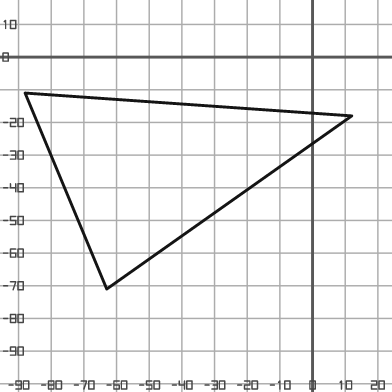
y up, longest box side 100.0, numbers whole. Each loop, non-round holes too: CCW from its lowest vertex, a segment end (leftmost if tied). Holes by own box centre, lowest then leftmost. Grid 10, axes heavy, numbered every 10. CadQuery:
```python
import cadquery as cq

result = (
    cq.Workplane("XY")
    .moveTo(-63.0, -71.0)
    .lineTo(12.0, -18.0)
    .lineTo(-88.0, -11.0)
    .close()
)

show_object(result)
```